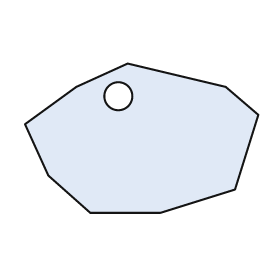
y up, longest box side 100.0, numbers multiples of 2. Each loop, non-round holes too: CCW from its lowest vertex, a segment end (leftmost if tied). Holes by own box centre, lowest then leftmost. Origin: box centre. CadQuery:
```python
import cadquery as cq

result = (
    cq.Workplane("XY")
    .moveTo(-22.0, -32.0)
    .lineTo(8.0, -32.0)
    .lineTo(40.0, -22.0)
    .lineTo(50.0, 10.0)
    .lineTo(36.0, 22.0)
    .lineTo(-6.0, 32.0)
    .lineTo(-28.0, 22.0)
    .lineTo(-50.0, 6.0)
    .lineTo(-40.0, -16.0)
    .close()
    .moveTo(-10.0, 18.0)
    .circle(6.0)
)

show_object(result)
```